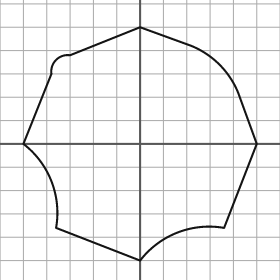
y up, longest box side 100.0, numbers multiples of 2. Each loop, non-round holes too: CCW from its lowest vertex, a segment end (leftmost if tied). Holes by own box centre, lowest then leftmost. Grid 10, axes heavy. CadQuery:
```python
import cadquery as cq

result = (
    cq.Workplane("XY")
    .moveTo(0.0, -50.0)
    .threePointArc((16.0, -38.0), (36.0, -36.0))
    .lineTo(50.0, 0.0)
    .lineTo(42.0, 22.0)
    .threePointArc((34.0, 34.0), (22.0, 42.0))
    .lineTo(0.0, 50.0)
    .lineTo(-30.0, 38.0)
    .threePointArc((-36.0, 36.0), (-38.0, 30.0))
    .lineTo(-50.0, 0.0)
    .threePointArc((-38.0, -16.0), (-36.0, -36.0))
    .close()
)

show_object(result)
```